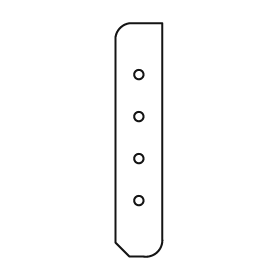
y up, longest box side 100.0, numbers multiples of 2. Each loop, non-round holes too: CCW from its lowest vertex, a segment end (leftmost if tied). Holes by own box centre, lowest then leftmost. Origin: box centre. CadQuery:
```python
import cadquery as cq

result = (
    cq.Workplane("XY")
    .moveTo(-4.0, -50.0)
    .lineTo(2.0, -50.0)
    .threePointArc((8.0, -48.0), (10.0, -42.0))
    .lineTo(10.0, 50.0)
    .lineTo(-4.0, 50.0)
    .threePointArc((-8.0, 48.0), (-10.0, 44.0))
    .lineTo(-10.0, -44.0)
    .close()
    .moveTo(0.0, -26.0)
    .circle(2.0)
    .moveTo(0.0, -8.0)
    .circle(2.0)
    .moveTo(0.0, 10.0)
    .circle(2.0)
    .moveTo(0.0, 28.0)
    .circle(2.0)
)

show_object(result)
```